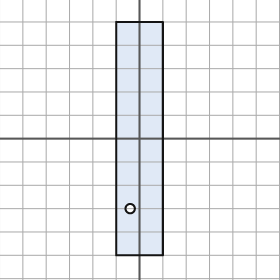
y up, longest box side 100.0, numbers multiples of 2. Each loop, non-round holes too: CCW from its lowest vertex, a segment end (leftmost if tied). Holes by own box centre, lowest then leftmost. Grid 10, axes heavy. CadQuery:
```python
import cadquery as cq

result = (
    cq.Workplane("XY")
    .moveTo(-10.0, -50.0)
    .lineTo(10.0, -50.0)
    .lineTo(10.0, 50.0)
    .lineTo(-10.0, 50.0)
    .close()
    .moveTo(-4.0, -30.0)
    .circle(2.0)
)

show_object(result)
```